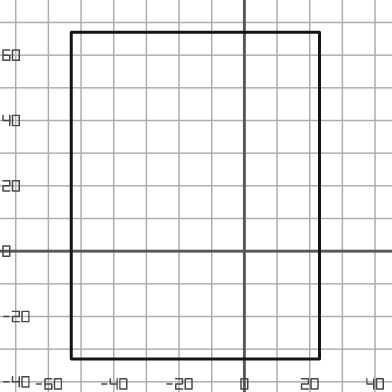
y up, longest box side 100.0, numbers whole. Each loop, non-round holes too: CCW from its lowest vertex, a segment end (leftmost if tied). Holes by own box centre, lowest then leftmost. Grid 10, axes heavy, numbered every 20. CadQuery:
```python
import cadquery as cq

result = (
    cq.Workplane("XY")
    .moveTo(-53.0, -33.0)
    .lineTo(23.0, -33.0)
    .lineTo(23.0, 67.0)
    .lineTo(-53.0, 67.0)
    .close()
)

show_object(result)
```